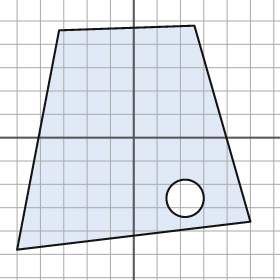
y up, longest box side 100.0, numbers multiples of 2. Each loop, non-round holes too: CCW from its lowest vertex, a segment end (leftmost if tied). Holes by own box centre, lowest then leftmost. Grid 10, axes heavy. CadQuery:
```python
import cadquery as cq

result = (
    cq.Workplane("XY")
    .moveTo(-50.0, -48.0)
    .lineTo(50.0, -36.0)
    .lineTo(26.0, 48.0)
    .lineTo(-32.0, 46.0)
    .close()
    .moveTo(22.0, -26.0)
    .circle(8.0)
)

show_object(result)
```